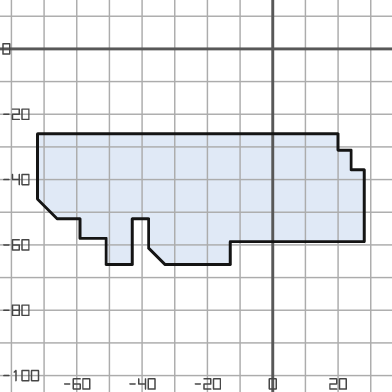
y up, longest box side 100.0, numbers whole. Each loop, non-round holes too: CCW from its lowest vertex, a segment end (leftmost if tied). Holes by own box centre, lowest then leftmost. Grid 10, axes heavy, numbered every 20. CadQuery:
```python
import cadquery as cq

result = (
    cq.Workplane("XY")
    .moveTo(-51.0, -66.0)
    .lineTo(-43.0, -66.0)
    .lineTo(-43.0, -52.0)
    .lineTo(-38.0, -52.0)
    .lineTo(-38.0, -61.0)
    .lineTo(-33.0, -66.0)
    .lineTo(-13.0, -66.0)
    .lineTo(-13.0, -59.0)
    .lineTo(28.0, -59.0)
    .lineTo(28.0, -37.0)
    .lineTo(24.0, -37.0)
    .lineTo(24.0, -31.0)
    .lineTo(20.0, -31.0)
    .lineTo(20.0, -26.0)
    .lineTo(-72.0, -26.0)
    .lineTo(-72.0, -46.0)
    .lineTo(-66.0, -52.0)
    .lineTo(-59.0, -52.0)
    .lineTo(-59.0, -58.0)
    .lineTo(-51.0, -58.0)
    .close()
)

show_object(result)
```